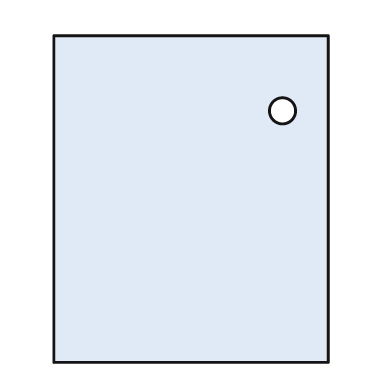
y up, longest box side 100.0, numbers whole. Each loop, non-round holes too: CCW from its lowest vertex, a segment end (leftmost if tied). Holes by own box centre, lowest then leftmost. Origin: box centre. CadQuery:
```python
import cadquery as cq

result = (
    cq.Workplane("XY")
    .moveTo(-42.0, -50.0)
    .lineTo(42.0, -50.0)
    .lineTo(42.0, 50.0)
    .lineTo(-42.0, 50.0)
    .close()
    .moveTo(28.0, 27.0)
    .circle(4.0)
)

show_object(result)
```